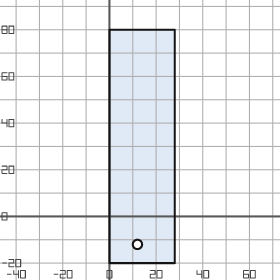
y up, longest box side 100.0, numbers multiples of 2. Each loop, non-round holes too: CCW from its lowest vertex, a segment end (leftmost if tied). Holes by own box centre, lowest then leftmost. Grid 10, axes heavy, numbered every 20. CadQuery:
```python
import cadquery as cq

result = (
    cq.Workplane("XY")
    .moveTo(0.0, -20.0)
    .lineTo(28.0, -20.0)
    .lineTo(28.0, 80.0)
    .lineTo(0.0, 80.0)
    .close()
    .moveTo(12.0, -12.0)
    .circle(2.0)
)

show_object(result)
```